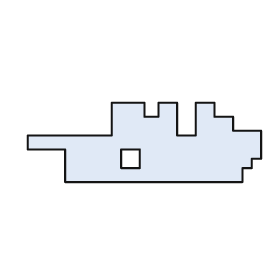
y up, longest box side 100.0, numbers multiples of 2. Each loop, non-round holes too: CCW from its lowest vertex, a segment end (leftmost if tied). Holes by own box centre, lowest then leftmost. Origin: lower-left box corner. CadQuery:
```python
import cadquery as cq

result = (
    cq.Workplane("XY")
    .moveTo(16.0, 0.0)
    .lineTo(92.0, 0.0)
    .lineTo(92.0, 6.0)
    .lineTo(96.0, 6.0)
    .lineTo(96.0, 10.0)
    .lineTo(100.0, 10.0)
    .lineTo(100.0, 22.0)
    .lineTo(88.0, 22.0)
    .lineTo(88.0, 28.0)
    .lineTo(80.0, 28.0)
    .lineTo(80.0, 34.0)
    .lineTo(72.0, 34.0)
    .lineTo(72.0, 20.0)
    .lineTo(64.0, 20.0)
    .lineTo(64.0, 34.0)
    .lineTo(56.0, 34.0)
    .lineTo(56.0, 28.0)
    .lineTo(50.0, 28.0)
    .lineTo(50.0, 34.0)
    .lineTo(36.0, 34.0)
    .lineTo(36.0, 20.0)
    .lineTo(0.0, 20.0)
    .lineTo(0.0, 14.0)
    .lineTo(16.0, 14.0)
    .close()
    .moveTo(40.0, 6.0)
    .lineTo(48.0, 6.0)
    .lineTo(48.0, 14.0)
    .lineTo(40.0, 14.0)
    .close()
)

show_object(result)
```